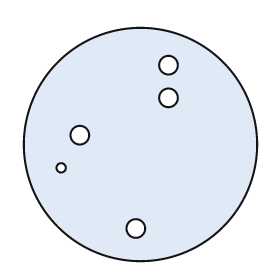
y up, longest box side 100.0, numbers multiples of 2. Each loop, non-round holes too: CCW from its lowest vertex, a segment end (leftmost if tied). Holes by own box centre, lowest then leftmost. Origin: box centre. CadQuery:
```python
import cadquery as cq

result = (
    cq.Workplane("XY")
    .moveTo(0.0, 0.0)
    .circle(50.0)
    .moveTo(-2.0, -36.0)
    .circle(4.0)
    .moveTo(-34.0, -10.0)
    .circle(2.0)
    .moveTo(-26.0, 4.0)
    .circle(4.0)
    .moveTo(12.0, 20.0)
    .circle(4.0)
    .moveTo(12.0, 34.0)
    .circle(4.0)
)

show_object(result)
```